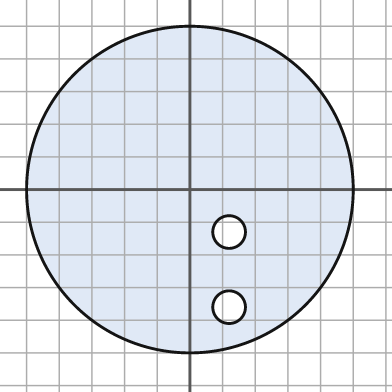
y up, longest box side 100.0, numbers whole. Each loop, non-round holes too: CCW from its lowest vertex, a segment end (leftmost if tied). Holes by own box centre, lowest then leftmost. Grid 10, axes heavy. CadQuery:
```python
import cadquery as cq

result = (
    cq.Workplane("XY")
    .moveTo(0.0, 0.0)
    .circle(50.0)
    .moveTo(12.0, -36.0)
    .circle(5.0)
    .moveTo(12.0, -13.0)
    .circle(5.0)
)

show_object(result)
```